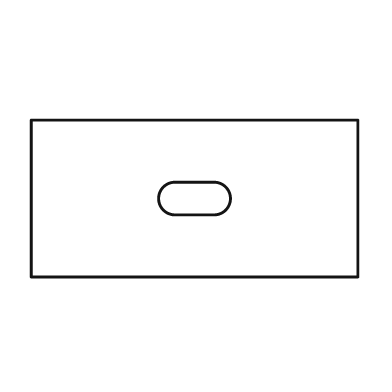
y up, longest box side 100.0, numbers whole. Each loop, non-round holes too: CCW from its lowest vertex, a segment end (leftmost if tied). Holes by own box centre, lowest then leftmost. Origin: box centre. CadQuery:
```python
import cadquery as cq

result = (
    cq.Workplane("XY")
    .moveTo(-50.0, -24.0)
    .lineTo(50.0, -24.0)
    .lineTo(50.0, 24.0)
    .lineTo(-50.0, 24.0)
    .close()
    .moveTo(-6.0, -5.0)
    .lineTo(6.0, -5.0)
    .threePointArc((11.0, 0.0), (6.0, 5.0))
    .lineTo(-6.0, 5.0)
    .threePointArc((-11.0, 0.0), (-6.0, -5.0))
    .close()
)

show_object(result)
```